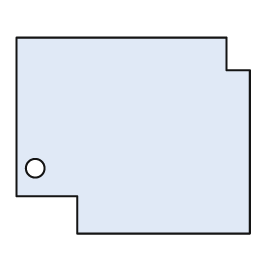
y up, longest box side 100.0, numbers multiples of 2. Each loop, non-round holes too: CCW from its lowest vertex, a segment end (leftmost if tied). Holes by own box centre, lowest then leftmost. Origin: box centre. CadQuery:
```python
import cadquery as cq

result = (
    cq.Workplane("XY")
    .moveTo(-24.0, -42.0)
    .lineTo(50.0, -42.0)
    .lineTo(50.0, 28.0)
    .lineTo(40.0, 28.0)
    .lineTo(40.0, 42.0)
    .lineTo(-50.0, 42.0)
    .lineTo(-50.0, -26.0)
    .lineTo(-24.0, -26.0)
    .close()
    .moveTo(-42.0, -14.0)
    .circle(4.0)
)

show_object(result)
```